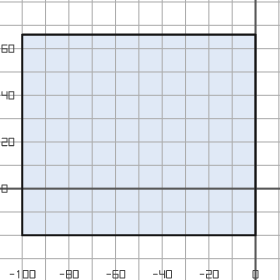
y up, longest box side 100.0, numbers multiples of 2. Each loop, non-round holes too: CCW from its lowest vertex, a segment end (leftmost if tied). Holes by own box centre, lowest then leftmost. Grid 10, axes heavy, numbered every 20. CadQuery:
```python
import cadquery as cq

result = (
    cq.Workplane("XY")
    .moveTo(-100.0, -20.0)
    .lineTo(0.0, -20.0)
    .lineTo(0.0, 66.0)
    .lineTo(-100.0, 66.0)
    .close()
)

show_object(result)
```